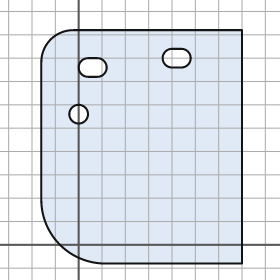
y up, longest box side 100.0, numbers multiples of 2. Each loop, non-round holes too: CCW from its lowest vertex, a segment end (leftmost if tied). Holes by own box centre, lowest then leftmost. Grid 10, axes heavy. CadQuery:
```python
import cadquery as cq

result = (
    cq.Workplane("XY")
    .moveTo(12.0, -8.0)
    .lineTo(70.0, -8.0)
    .lineTo(70.0, 92.0)
    .lineTo(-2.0, 92.0)
    .threePointArc((-12.0, 88.0), (-16.0, 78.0))
    .lineTo(-16.0, 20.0)
    .threePointArc((-8.0, 0.0), (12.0, -8.0))
    .close()
    .moveTo(0.0, 56.0)
    .circle(4.0)
    .moveTo(4.0, 72.0)
    .lineTo(8.0, 72.0)
    .threePointArc((12.0, 76.0), (8.0, 80.0))
    .lineTo(4.0, 80.0)
    .threePointArc((0.0, 76.0), (4.0, 72.0))
    .close()
    .moveTo(40.0, 76.0)
    .lineTo(44.0, 76.0)
    .threePointArc((48.0, 80.0), (44.0, 84.0))
    .lineTo(40.0, 84.0)
    .threePointArc((36.0, 80.0), (40.0, 76.0))
    .close()
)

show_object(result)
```